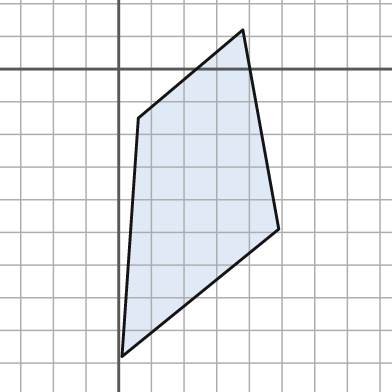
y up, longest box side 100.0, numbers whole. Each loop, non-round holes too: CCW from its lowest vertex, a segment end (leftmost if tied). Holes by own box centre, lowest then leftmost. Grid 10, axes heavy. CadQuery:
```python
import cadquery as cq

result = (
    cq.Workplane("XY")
    .moveTo(1.0, -88.0)
    .lineTo(49.0, -49.0)
    .lineTo(38.0, 12.0)
    .lineTo(6.0, -15.0)
    .close()
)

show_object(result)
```